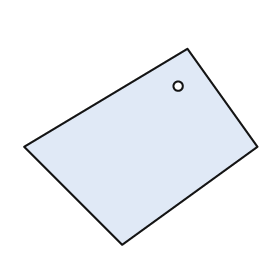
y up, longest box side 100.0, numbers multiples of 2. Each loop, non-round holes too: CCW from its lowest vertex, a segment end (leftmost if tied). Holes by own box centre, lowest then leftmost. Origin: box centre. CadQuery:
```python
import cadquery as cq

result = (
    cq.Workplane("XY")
    .moveTo(-8.0, -42.0)
    .lineTo(50.0, 0.0)
    .lineTo(20.0, 42.0)
    .lineTo(-50.0, 0.0)
    .close()
    .moveTo(16.0, 26.0)
    .circle(2.0)
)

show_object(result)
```